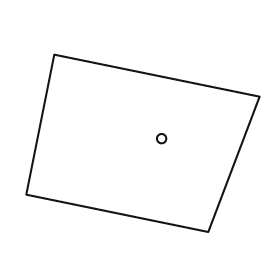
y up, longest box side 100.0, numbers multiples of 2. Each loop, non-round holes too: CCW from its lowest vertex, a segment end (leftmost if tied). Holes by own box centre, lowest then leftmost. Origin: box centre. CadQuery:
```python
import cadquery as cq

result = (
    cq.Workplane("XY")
    .moveTo(28.0, -38.0)
    .lineTo(50.0, 20.0)
    .lineTo(-38.0, 38.0)
    .lineTo(-50.0, -22.0)
    .close()
    .moveTo(8.0, 2.0)
    .circle(2.0)
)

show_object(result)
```